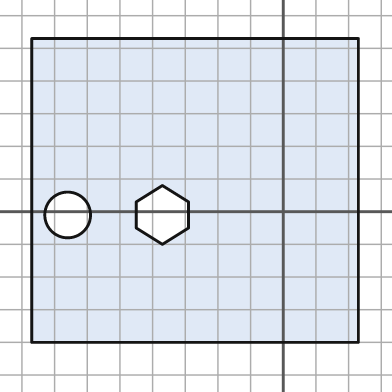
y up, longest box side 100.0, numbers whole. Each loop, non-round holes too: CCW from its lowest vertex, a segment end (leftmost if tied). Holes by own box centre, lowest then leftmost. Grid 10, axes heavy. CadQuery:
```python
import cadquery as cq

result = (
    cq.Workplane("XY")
    .moveTo(-77.0, -40.0)
    .lineTo(23.0, -40.0)
    .lineTo(23.0, 53.0)
    .lineTo(-77.0, 53.0)
    .close()
    .moveTo(-66.0, -1.0)
    .circle(7.0)
    .moveTo(-37.0, -10.0)
    .lineTo(-29.0, -5.0)
    .lineTo(-29.0, 3.0)
    .lineTo(-37.0, 8.0)
    .lineTo(-45.0, 3.0)
    .lineTo(-45.0, -5.0)
    .close()
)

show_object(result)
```